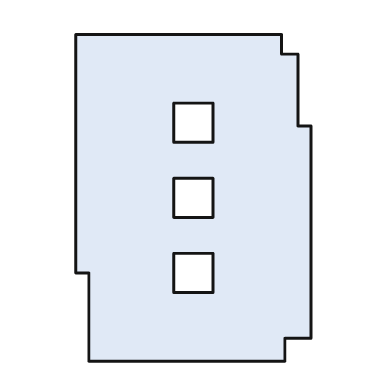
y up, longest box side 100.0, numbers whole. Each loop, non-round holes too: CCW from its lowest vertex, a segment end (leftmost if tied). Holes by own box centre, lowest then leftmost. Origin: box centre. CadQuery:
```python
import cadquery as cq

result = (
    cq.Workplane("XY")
    .moveTo(-32.0, -50.0)
    .lineTo(28.0, -50.0)
    .lineTo(28.0, -43.0)
    .lineTo(36.0, -43.0)
    .lineTo(36.0, 22.0)
    .lineTo(32.0, 22.0)
    .lineTo(32.0, 44.0)
    .lineTo(27.0, 44.0)
    .lineTo(27.0, 50.0)
    .lineTo(-36.0, 50.0)
    .lineTo(-36.0, -23.0)
    .lineTo(-32.0, -23.0)
    .close()
    .moveTo(-6.0, -29.0)
    .lineTo(6.0, -29.0)
    .lineTo(6.0, -17.0)
    .lineTo(-6.0, -17.0)
    .close()
    .moveTo(-6.0, -6.0)
    .lineTo(6.0, -6.0)
    .lineTo(6.0, 6.0)
    .lineTo(-6.0, 6.0)
    .close()
    .moveTo(-6.0, 17.0)
    .lineTo(6.0, 17.0)
    .lineTo(6.0, 29.0)
    .lineTo(-6.0, 29.0)
    .close()
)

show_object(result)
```